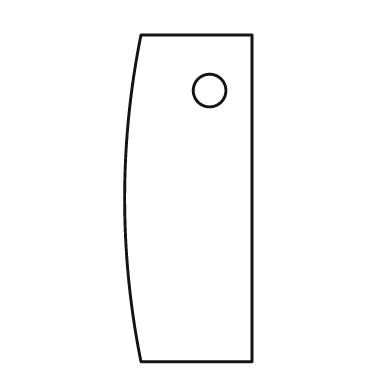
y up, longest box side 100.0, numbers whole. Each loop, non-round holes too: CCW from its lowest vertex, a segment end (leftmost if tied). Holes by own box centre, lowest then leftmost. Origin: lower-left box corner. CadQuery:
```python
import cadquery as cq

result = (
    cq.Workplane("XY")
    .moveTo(5.0, 0.0)
    .lineTo(39.0, 0.0)
    .lineTo(39.0, 100.0)
    .lineTo(5.0, 100.0)
    .threePointArc((0.0, 50.0), (5.0, 0.0))
    .close()
    .moveTo(26.0, 83.0)
    .circle(5.0)
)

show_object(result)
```